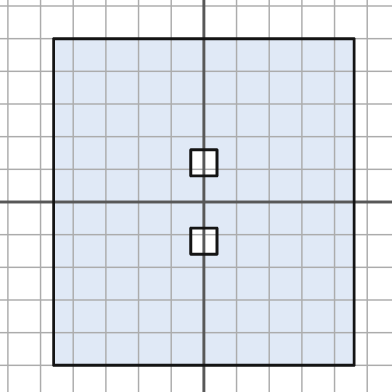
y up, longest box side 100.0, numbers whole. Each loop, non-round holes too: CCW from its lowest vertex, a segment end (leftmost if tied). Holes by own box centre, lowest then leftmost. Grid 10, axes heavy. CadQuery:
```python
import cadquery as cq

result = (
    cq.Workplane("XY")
    .moveTo(-46.0, -50.0)
    .lineTo(46.0, -50.0)
    .lineTo(46.0, 50.0)
    .lineTo(-46.0, 50.0)
    .close()
    .moveTo(-4.0, -16.0)
    .lineTo(4.0, -16.0)
    .lineTo(4.0, -8.0)
    .lineTo(-4.0, -8.0)
    .close()
    .moveTo(-4.0, 8.0)
    .lineTo(4.0, 8.0)
    .lineTo(4.0, 16.0)
    .lineTo(-4.0, 16.0)
    .close()
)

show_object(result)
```